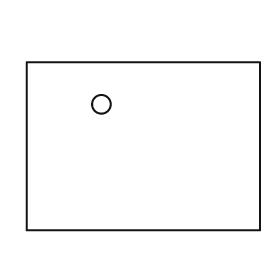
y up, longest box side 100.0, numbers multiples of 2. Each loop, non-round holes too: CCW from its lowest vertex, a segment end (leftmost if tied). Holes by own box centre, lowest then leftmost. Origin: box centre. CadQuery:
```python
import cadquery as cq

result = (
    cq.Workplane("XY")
    .moveTo(-50.0, -36.0)
    .lineTo(50.0, -36.0)
    .lineTo(50.0, 36.0)
    .lineTo(-50.0, 36.0)
    .close()
    .moveTo(-18.0, 18.0)
    .circle(4.0)
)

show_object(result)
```